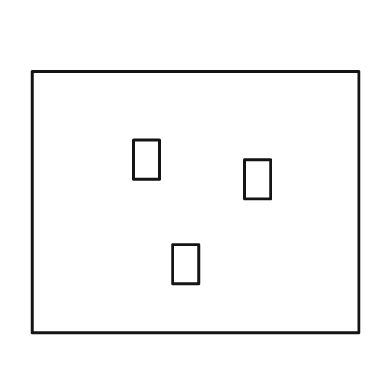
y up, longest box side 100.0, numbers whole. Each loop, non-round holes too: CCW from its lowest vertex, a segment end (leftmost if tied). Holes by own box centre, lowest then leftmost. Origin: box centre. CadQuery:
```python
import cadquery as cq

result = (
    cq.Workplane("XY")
    .moveTo(-50.0, -40.0)
    .lineTo(50.0, -40.0)
    .lineTo(50.0, 40.0)
    .lineTo(-50.0, 40.0)
    .close()
    .moveTo(-7.0, -25.0)
    .lineTo(1.0, -25.0)
    .lineTo(1.0, -13.0)
    .lineTo(-7.0, -13.0)
    .close()
    .moveTo(15.0, 1.0)
    .lineTo(23.0, 1.0)
    .lineTo(23.0, 13.0)
    .lineTo(15.0, 13.0)
    .close()
    .moveTo(-19.0, 7.0)
    .lineTo(-11.0, 7.0)
    .lineTo(-11.0, 19.0)
    .lineTo(-19.0, 19.0)
    .close()
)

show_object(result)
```